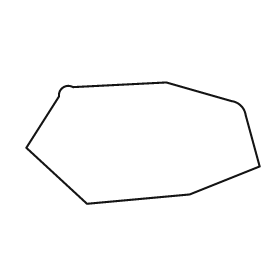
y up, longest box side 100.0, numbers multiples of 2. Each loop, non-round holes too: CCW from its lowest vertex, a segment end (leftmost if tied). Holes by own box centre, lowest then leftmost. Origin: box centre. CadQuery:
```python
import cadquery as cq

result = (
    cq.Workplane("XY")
    .moveTo(-24.0, -26.0)
    .lineTo(20.0, -22.0)
    .lineTo(50.0, -10.0)
    .lineTo(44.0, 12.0)
    .threePointArc((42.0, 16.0), (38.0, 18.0))
    .lineTo(10.0, 26.0)
    .lineTo(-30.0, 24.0)
    .threePointArc((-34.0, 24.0), (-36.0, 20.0))
    .lineTo(-50.0, -2.0)
    .close()
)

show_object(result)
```